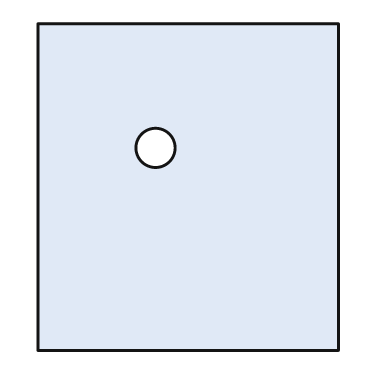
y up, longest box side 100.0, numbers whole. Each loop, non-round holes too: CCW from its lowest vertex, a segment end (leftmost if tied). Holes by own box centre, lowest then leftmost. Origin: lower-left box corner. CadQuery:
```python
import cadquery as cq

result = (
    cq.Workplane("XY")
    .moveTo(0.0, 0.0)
    .lineTo(92.0, 0.0)
    .lineTo(92.0, 100.0)
    .lineTo(0.0, 100.0)
    .close()
    .moveTo(36.0, 62.0)
    .circle(6.0)
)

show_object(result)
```